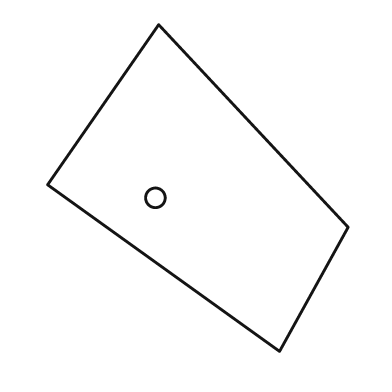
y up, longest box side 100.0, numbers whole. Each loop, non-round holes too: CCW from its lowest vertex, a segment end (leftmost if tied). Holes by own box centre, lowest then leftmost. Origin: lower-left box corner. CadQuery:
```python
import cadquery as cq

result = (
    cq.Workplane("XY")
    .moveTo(71.0, 0.0)
    .lineTo(92.0, 38.0)
    .lineTo(34.0, 100.0)
    .lineTo(0.0, 51.0)
    .close()
    .moveTo(33.0, 47.0)
    .circle(3.0)
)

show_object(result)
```